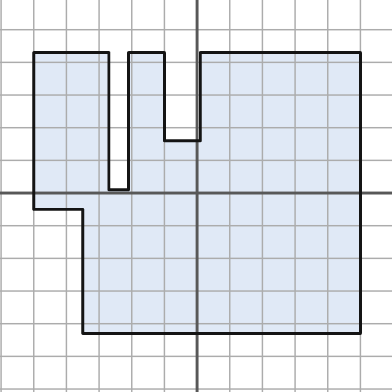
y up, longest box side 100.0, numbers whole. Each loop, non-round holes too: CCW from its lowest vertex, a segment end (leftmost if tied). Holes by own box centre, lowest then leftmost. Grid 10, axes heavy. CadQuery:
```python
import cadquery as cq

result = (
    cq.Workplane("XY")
    .moveTo(-35.0, -43.0)
    .lineTo(50.0, -43.0)
    .lineTo(50.0, 43.0)
    .lineTo(1.0, 43.0)
    .lineTo(1.0, 16.0)
    .lineTo(-10.0, 16.0)
    .lineTo(-10.0, 43.0)
    .lineTo(-21.0, 43.0)
    .lineTo(-21.0, 1.0)
    .lineTo(-27.0, 1.0)
    .lineTo(-27.0, 43.0)
    .lineTo(-50.0, 43.0)
    .lineTo(-50.0, -5.0)
    .lineTo(-35.0, -5.0)
    .close()
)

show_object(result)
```